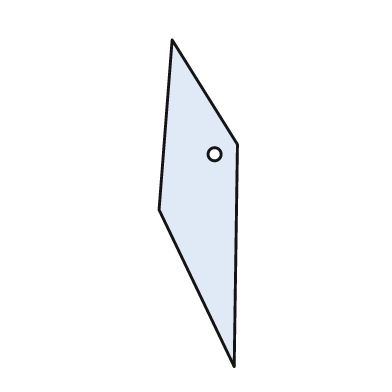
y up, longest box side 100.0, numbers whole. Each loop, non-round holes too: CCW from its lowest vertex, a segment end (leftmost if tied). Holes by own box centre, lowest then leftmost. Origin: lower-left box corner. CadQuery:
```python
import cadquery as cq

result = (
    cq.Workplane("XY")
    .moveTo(23.0, 0.0)
    .lineTo(24.0, 68.0)
    .lineTo(4.0, 100.0)
    .lineTo(0.0, 48.0)
    .close()
    .moveTo(17.0, 65.0)
    .circle(2.0)
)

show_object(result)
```